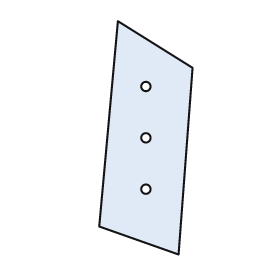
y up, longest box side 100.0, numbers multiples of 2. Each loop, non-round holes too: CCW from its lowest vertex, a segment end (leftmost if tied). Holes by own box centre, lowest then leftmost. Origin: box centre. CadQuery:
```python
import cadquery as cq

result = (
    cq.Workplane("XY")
    .moveTo(14.0, -50.0)
    .lineTo(20.0, 30.0)
    .lineTo(-12.0, 50.0)
    .lineTo(-20.0, -38.0)
    .close()
    .moveTo(0.0, -22.0)
    .circle(2.0)
    .moveTo(0.0, 0.0)
    .circle(2.0)
    .moveTo(0.0, 22.0)
    .circle(2.0)
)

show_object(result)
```